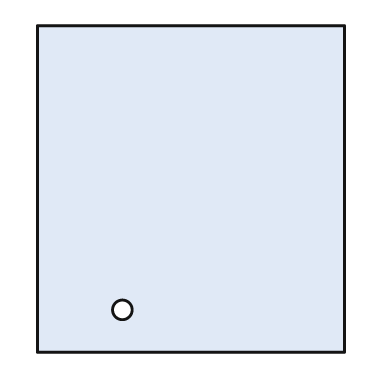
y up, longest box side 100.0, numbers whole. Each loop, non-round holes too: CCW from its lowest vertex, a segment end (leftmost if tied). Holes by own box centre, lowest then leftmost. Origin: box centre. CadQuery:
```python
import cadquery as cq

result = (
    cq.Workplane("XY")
    .moveTo(-47.0, -50.0)
    .lineTo(47.0, -50.0)
    .lineTo(47.0, 50.0)
    .lineTo(-47.0, 50.0)
    .close()
    .moveTo(-21.0, -37.0)
    .circle(3.0)
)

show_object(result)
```